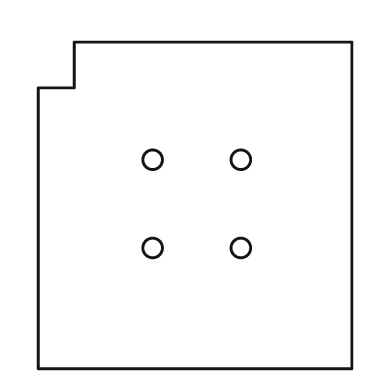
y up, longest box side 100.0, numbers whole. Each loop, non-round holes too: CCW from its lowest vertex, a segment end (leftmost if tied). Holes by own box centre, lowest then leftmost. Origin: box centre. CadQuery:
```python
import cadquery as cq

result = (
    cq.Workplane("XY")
    .moveTo(-48.0, -50.0)
    .lineTo(48.0, -50.0)
    .lineTo(48.0, 50.0)
    .lineTo(-37.0, 50.0)
    .lineTo(-37.0, 36.0)
    .lineTo(-48.0, 36.0)
    .close()
    .moveTo(-13.0, -13.0)
    .circle(3.0)
    .moveTo(14.0, -13.0)
    .circle(3.0)
    .moveTo(-13.0, 14.0)
    .circle(3.0)
    .moveTo(14.0, 14.0)
    .circle(3.0)
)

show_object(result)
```